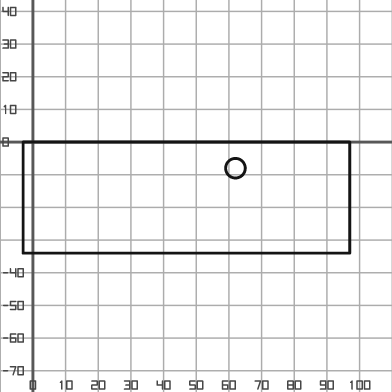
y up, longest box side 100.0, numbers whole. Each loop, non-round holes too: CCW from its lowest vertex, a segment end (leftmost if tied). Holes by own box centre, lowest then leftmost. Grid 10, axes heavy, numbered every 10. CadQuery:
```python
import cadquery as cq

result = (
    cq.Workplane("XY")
    .moveTo(-3.0, -34.0)
    .lineTo(97.0, -34.0)
    .lineTo(97.0, 0.0)
    .lineTo(-3.0, 0.0)
    .close()
    .moveTo(62.0, -8.0)
    .circle(3.0)
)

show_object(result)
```